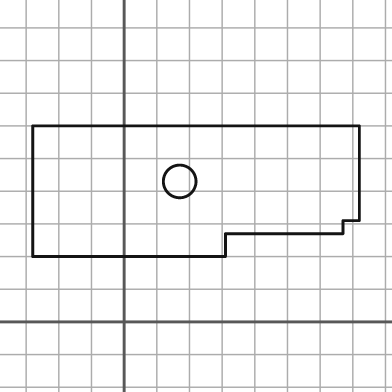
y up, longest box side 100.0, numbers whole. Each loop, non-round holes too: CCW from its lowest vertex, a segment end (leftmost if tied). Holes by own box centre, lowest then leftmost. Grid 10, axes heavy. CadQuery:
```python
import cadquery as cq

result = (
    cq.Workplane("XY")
    .moveTo(-28.0, 20.0)
    .lineTo(31.0, 20.0)
    .lineTo(31.0, 27.0)
    .lineTo(67.0, 27.0)
    .lineTo(67.0, 31.0)
    .lineTo(72.0, 31.0)
    .lineTo(72.0, 60.0)
    .lineTo(-28.0, 60.0)
    .close()
    .moveTo(17.0, 43.0)
    .circle(5.0)
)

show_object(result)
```